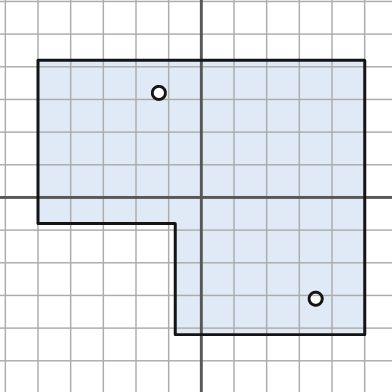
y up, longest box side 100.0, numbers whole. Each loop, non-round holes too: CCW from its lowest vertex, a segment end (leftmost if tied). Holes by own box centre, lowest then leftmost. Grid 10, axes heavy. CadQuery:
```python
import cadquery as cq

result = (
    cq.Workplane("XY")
    .moveTo(-8.0, -42.0)
    .lineTo(50.0, -42.0)
    .lineTo(50.0, 42.0)
    .lineTo(-50.0, 42.0)
    .lineTo(-50.0, -8.0)
    .lineTo(-8.0, -8.0)
    .close()
    .moveTo(35.0, -31.0)
    .circle(2.0)
    .moveTo(-13.0, 32.0)
    .circle(2.0)
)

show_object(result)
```